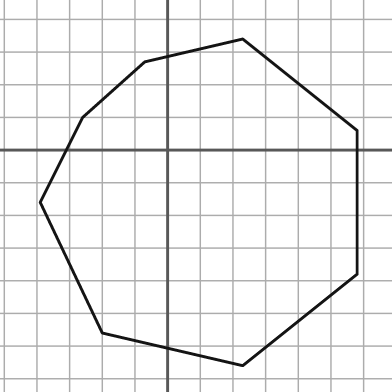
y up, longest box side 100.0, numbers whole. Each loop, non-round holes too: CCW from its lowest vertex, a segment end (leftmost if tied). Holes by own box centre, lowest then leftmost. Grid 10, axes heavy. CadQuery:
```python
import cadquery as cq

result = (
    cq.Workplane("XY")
    .moveTo(23.0, -66.0)
    .lineTo(58.0, -38.0)
    .lineTo(58.0, 6.0)
    .lineTo(23.0, 34.0)
    .lineTo(-7.0, 27.0)
    .lineTo(-26.0, 10.0)
    .lineTo(-39.0, -16.0)
    .lineTo(-20.0, -56.0)
    .close()
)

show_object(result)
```